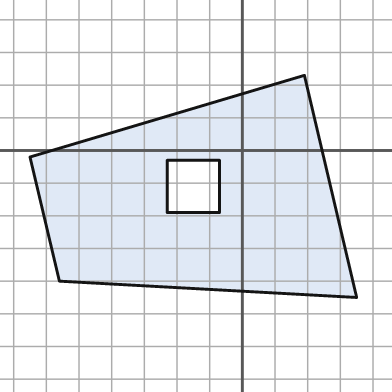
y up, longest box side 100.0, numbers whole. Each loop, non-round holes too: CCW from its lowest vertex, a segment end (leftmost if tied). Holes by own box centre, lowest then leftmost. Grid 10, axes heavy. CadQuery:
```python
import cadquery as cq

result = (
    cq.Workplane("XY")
    .moveTo(35.0, -45.0)
    .lineTo(19.0, 23.0)
    .lineTo(-65.0, -2.0)
    .lineTo(-56.0, -40.0)
    .close()
    .moveTo(-23.0, -19.0)
    .lineTo(-7.0, -19.0)
    .lineTo(-7.0, -3.0)
    .lineTo(-23.0, -3.0)
    .close()
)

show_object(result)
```